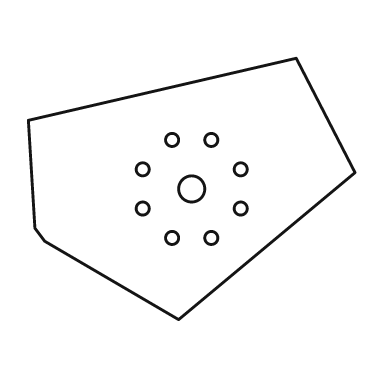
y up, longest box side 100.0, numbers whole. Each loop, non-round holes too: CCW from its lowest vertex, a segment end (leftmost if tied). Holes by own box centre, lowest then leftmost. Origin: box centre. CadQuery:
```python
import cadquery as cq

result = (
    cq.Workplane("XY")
    .moveTo(-4.0, -40.0)
    .lineTo(50.0, 5.0)
    .lineTo(32.0, 40.0)
    .lineTo(-50.0, 21.0)
    .lineTo(-48.0, -12.0)
    .lineTo(-45.0, -16.0)
    .close()
    .moveTo(-6.0, -15.0)
    .circle(2.0)
    .moveTo(6.0, -15.0)
    .circle(2.0)
    .moveTo(-15.0, -6.0)
    .circle(2.0)
    .moveTo(15.0, -6.0)
    .circle(2.0)
    .moveTo(0.0, 0.0)
    .circle(4.0)
    .moveTo(-15.0, 6.0)
    .circle(2.0)
    .moveTo(15.0, 6.0)
    .circle(2.0)
    .moveTo(-6.0, 15.0)
    .circle(2.0)
    .moveTo(6.0, 15.0)
    .circle(2.0)
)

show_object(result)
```